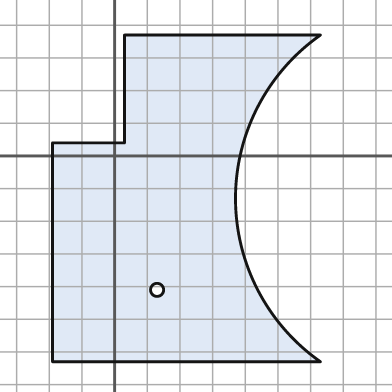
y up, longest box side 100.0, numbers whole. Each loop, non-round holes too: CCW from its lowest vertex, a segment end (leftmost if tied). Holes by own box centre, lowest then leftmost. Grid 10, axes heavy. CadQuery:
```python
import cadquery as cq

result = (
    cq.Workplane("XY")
    .moveTo(-19.0, -63.0)
    .lineTo(63.0, -63.0)
    .threePointArc((37.0, -13.0), (63.0, 37.0))
    .lineTo(3.0, 37.0)
    .lineTo(3.0, 4.0)
    .lineTo(-19.0, 4.0)
    .close()
    .moveTo(13.0, -41.0)
    .circle(2.0)
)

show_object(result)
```